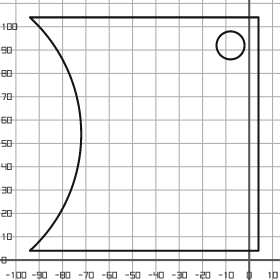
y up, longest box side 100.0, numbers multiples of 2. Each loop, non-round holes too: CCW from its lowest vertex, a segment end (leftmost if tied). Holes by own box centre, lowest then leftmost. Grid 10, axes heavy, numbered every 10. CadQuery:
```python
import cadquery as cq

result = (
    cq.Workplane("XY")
    .moveTo(-94.0, 4.0)
    .lineTo(4.0, 4.0)
    .lineTo(4.0, 104.0)
    .lineTo(-94.0, 104.0)
    .threePointArc((-72.0, 54.0), (-94.0, 4.0))
    .close()
    .moveTo(-8.0, 92.0)
    .circle(6.0)
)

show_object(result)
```